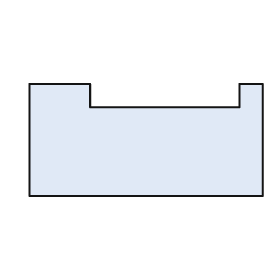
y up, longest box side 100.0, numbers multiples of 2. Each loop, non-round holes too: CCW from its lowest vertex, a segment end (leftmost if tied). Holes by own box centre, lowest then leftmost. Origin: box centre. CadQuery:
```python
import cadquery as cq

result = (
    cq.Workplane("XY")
    .moveTo(-50.0, -24.0)
    .lineTo(50.0, -24.0)
    .lineTo(50.0, 24.0)
    .lineTo(40.0, 24.0)
    .lineTo(40.0, 14.0)
    .lineTo(-24.0, 14.0)
    .lineTo(-24.0, 24.0)
    .lineTo(-50.0, 24.0)
    .close()
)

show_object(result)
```